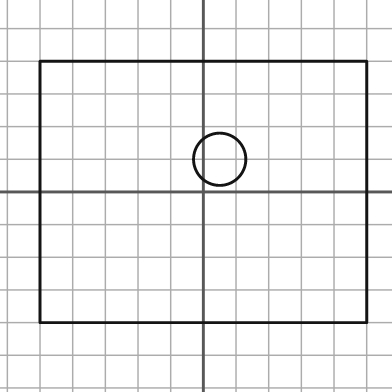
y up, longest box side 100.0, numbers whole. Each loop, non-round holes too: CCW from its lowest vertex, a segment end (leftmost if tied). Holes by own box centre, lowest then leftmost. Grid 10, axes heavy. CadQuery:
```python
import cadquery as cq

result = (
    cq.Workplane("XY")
    .moveTo(-50.0, -40.0)
    .lineTo(50.0, -40.0)
    .lineTo(50.0, 40.0)
    .lineTo(-50.0, 40.0)
    .close()
    .moveTo(5.0, 10.0)
    .circle(8.0)
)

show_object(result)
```